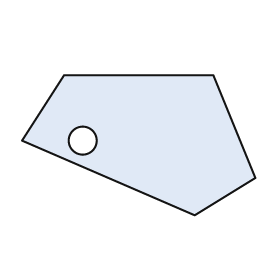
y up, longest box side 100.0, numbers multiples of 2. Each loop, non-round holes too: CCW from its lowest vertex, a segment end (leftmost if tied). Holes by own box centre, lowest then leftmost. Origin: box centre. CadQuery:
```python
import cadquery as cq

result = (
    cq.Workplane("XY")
    .moveTo(24.0, -30.0)
    .lineTo(50.0, -14.0)
    .lineTo(32.0, 30.0)
    .lineTo(-32.0, 30.0)
    .lineTo(-50.0, 2.0)
    .close()
    .moveTo(-24.0, 2.0)
    .circle(6.0)
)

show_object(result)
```